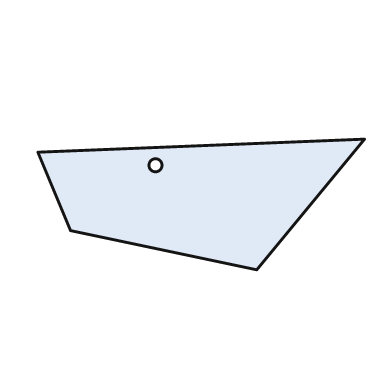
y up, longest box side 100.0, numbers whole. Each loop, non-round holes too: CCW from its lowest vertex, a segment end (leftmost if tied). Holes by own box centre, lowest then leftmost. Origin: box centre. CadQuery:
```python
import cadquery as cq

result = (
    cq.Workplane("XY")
    .moveTo(17.0, -20.0)
    .lineTo(50.0, 20.0)
    .lineTo(-50.0, 16.0)
    .lineTo(-40.0, -8.0)
    .close()
    .moveTo(-14.0, 12.0)
    .circle(2.0)
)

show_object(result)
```